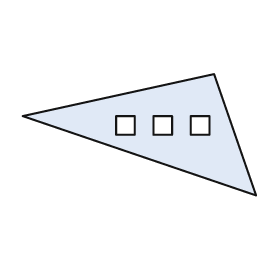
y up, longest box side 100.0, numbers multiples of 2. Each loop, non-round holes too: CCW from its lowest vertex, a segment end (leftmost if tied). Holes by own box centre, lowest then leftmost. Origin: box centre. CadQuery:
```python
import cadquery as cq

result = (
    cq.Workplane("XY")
    .moveTo(50.0, -26.0)
    .lineTo(32.0, 26.0)
    .lineTo(-50.0, 8.0)
    .close()
    .moveTo(-10.0, 0.0)
    .lineTo(-2.0, 0.0)
    .lineTo(-2.0, 8.0)
    .lineTo(-10.0, 8.0)
    .close()
    .moveTo(6.0, 0.0)
    .lineTo(14.0, 0.0)
    .lineTo(14.0, 8.0)
    .lineTo(6.0, 8.0)
    .close()
    .moveTo(22.0, 0.0)
    .lineTo(30.0, 0.0)
    .lineTo(30.0, 8.0)
    .lineTo(22.0, 8.0)
    .close()
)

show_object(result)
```